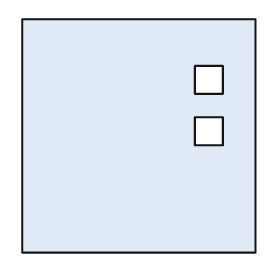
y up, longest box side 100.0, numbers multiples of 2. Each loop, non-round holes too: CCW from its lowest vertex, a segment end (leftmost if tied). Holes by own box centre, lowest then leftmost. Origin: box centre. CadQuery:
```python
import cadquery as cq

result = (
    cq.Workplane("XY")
    .moveTo(-50.0, -50.0)
    .lineTo(50.0, -50.0)
    .lineTo(50.0, 50.0)
    .lineTo(-50.0, 50.0)
    .close()
    .moveTo(24.0, -4.0)
    .lineTo(36.0, -4.0)
    .lineTo(36.0, 8.0)
    .lineTo(24.0, 8.0)
    .close()
    .moveTo(24.0, 18.0)
    .lineTo(36.0, 18.0)
    .lineTo(36.0, 30.0)
    .lineTo(24.0, 30.0)
    .close()
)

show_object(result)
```